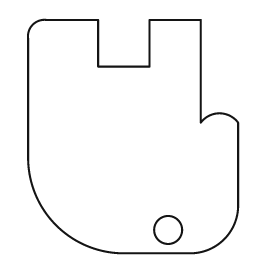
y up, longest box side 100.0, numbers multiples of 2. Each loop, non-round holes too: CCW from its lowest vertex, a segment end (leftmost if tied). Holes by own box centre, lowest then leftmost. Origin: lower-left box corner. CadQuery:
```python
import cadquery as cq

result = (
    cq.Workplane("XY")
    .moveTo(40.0, 0.0)
    .lineTo(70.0, 0.0)
    .threePointArc((84.0, 6.0), (90.0, 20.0))
    .lineTo(90.0, 56.0)
    .threePointArc((82.0, 60.0), (74.0, 56.0))
    .lineTo(74.0, 100.0)
    .lineTo(52.0, 100.0)
    .lineTo(52.0, 80.0)
    .lineTo(30.0, 80.0)
    .lineTo(30.0, 100.0)
    .lineTo(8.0, 100.0)
    .threePointArc((2.0, 98.0), (0.0, 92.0))
    .lineTo(0.0, 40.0)
    .threePointArc((12.0, 12.0), (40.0, 0.0))
    .close()
    .moveTo(60.0, 10.0)
    .circle(6.0)
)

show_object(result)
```